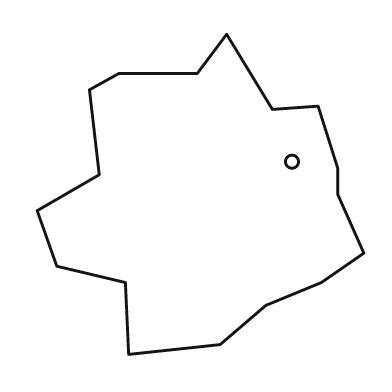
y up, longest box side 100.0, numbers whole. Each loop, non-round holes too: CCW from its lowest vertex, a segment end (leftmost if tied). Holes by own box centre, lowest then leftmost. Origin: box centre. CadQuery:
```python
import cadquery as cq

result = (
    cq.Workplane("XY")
    .moveTo(-22.0, -49.0)
    .lineTo(6.0, -46.0)
    .lineTo(20.0, -34.0)
    .lineTo(37.0, -27.0)
    .lineTo(50.0, -18.0)
    .lineTo(42.0, 0.0)
    .lineTo(42.0, 8.0)
    .lineTo(36.0, 27.0)
    .lineTo(22.0, 26.0)
    .lineTo(8.0, 49.0)
    .lineTo(-1.0, 37.0)
    .lineTo(-25.0, 37.0)
    .lineTo(-34.0, 32.0)
    .lineTo(-31.0, 6.0)
    .lineTo(-50.0, -5.0)
    .lineTo(-44.0, -22.0)
    .lineTo(-23.0, -27.0)
    .close()
    .moveTo(28.0, 10.0)
    .circle(2.0)
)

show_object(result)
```